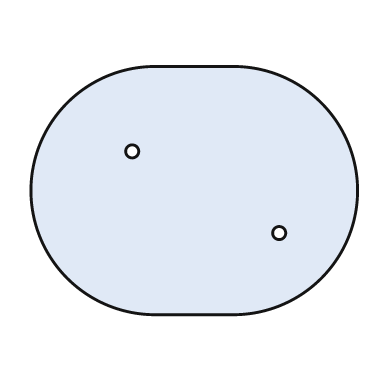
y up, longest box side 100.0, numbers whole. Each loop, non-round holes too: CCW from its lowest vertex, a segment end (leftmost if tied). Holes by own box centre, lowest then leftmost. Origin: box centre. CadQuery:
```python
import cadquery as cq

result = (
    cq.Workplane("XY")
    .moveTo(-12.0, -38.0)
    .lineTo(12.0, -38.0)
    .threePointArc((50.0, 0.0), (12.0, 38.0))
    .lineTo(-12.0, 38.0)
    .threePointArc((-50.0, 0.0), (-12.0, -38.0))
    .close()
    .moveTo(26.0, -13.0)
    .circle(2.0)
    .moveTo(-19.0, 12.0)
    .circle(2.0)
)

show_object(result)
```